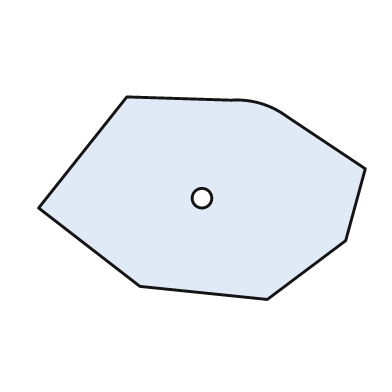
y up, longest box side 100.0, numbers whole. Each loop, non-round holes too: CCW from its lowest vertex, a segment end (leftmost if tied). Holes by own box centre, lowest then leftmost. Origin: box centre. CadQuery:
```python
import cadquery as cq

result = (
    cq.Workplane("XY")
    .moveTo(20.0, -31.0)
    .lineTo(44.0, -13.0)
    .lineTo(50.0, 9.0)
    .lineTo(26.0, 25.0)
    .threePointArc((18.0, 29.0), (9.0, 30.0))
    .lineTo(-23.0, 31.0)
    .lineTo(-50.0, -3.0)
    .lineTo(-19.0, -27.0)
    .close()
    .moveTo(0.0, 0.0)
    .circle(3.0)
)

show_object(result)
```